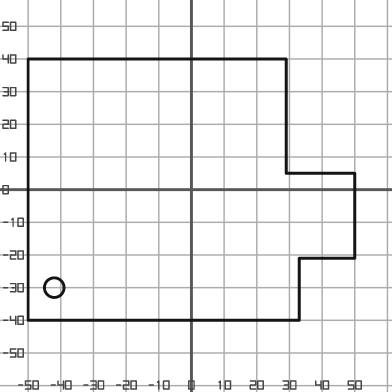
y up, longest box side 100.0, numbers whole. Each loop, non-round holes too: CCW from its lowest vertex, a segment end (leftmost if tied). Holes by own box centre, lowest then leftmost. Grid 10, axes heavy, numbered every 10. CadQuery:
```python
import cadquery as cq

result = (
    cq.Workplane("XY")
    .moveTo(-50.0, -40.0)
    .lineTo(33.0, -40.0)
    .lineTo(33.0, -21.0)
    .lineTo(50.0, -21.0)
    .lineTo(50.0, 5.0)
    .lineTo(29.0, 5.0)
    .lineTo(29.0, 40.0)
    .lineTo(-50.0, 40.0)
    .close()
    .moveTo(-42.0, -30.0)
    .circle(3.0)
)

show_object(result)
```